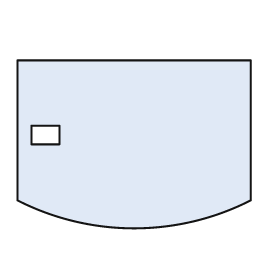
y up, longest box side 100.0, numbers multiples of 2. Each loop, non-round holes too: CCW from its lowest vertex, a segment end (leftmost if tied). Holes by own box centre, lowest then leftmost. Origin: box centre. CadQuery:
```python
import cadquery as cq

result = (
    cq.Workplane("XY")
    .moveTo(-50.0, -24.0)
    .threePointArc((0.0, -36.0), (50.0, -24.0))
    .lineTo(50.0, 36.0)
    .lineTo(-50.0, 36.0)
    .close()
    .moveTo(-44.0, 0.0)
    .lineTo(-32.0, 0.0)
    .lineTo(-32.0, 8.0)
    .lineTo(-44.0, 8.0)
    .close()
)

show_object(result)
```